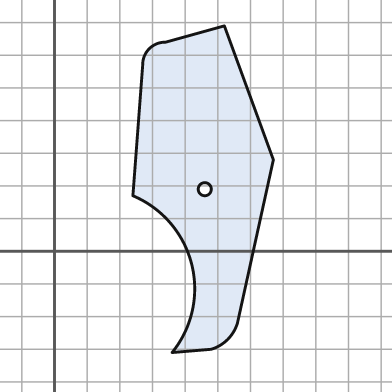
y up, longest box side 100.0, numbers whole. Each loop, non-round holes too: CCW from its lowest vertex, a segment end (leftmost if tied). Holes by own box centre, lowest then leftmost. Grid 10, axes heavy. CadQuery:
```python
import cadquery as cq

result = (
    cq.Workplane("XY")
    .moveTo(36.0, -31.0)
    .lineTo(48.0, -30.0)
    .threePointArc((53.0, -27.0), (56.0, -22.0))
    .lineTo(67.0, 28.0)
    .lineTo(52.0, 69.0)
    .lineTo(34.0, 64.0)
    .threePointArc((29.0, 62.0), (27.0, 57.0))
    .lineTo(24.0, 17.0)
    .threePointArc((42.0, -4.0), (36.0, -31.0))
    .close()
    .moveTo(46.0, 19.0)
    .circle(2.0)
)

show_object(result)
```